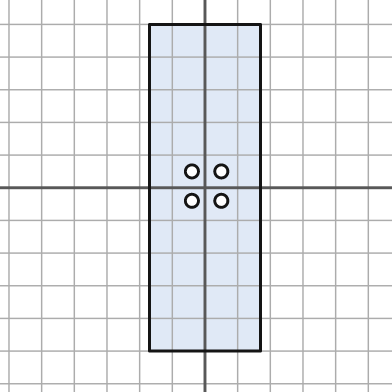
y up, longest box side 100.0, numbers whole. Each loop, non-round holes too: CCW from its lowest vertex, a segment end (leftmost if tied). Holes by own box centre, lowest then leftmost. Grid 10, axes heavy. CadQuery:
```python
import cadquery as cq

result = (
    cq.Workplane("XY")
    .moveTo(-17.0, -50.0)
    .lineTo(17.0, -50.0)
    .lineTo(17.0, 50.0)
    .lineTo(-17.0, 50.0)
    .close()
    .moveTo(-4.0, -4.0)
    .circle(2.0)
    .moveTo(5.0, -4.0)
    .circle(2.0)
    .moveTo(-4.0, 5.0)
    .circle(2.0)
    .moveTo(5.0, 5.0)
    .circle(2.0)
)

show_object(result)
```